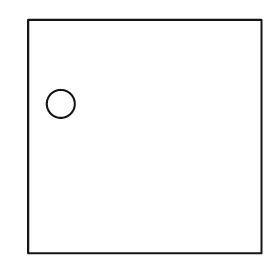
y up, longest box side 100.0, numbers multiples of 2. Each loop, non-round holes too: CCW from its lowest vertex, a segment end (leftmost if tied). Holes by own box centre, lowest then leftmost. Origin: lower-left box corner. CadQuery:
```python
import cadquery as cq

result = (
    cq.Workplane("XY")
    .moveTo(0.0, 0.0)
    .lineTo(100.0, 0.0)
    .lineTo(100.0, 100.0)
    .lineTo(0.0, 100.0)
    .close()
    .moveTo(14.0, 64.0)
    .circle(6.0)
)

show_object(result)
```